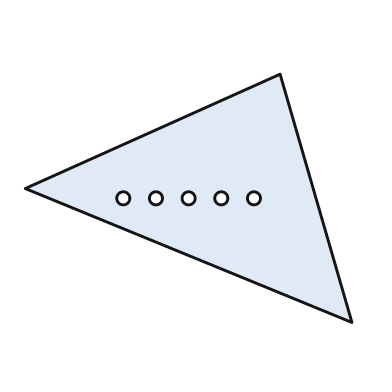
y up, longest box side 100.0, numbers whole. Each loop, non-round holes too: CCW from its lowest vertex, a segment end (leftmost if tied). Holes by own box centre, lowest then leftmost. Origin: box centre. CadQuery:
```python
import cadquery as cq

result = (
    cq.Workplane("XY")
    .moveTo(50.0, -38.0)
    .lineTo(28.0, 38.0)
    .lineTo(-50.0, 3.0)
    .close()
    .moveTo(-20.0, 0.0)
    .circle(2.0)
    .moveTo(-10.0, 0.0)
    .circle(2.0)
    .moveTo(0.0, 0.0)
    .circle(2.0)
    .moveTo(10.0, 0.0)
    .circle(2.0)
    .moveTo(20.0, 0.0)
    .circle(2.0)
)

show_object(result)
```